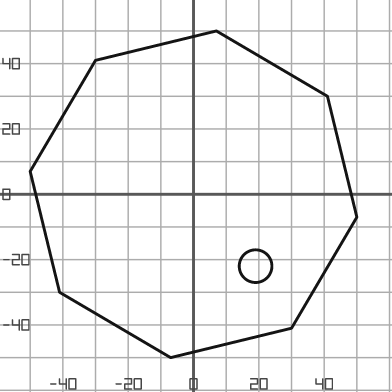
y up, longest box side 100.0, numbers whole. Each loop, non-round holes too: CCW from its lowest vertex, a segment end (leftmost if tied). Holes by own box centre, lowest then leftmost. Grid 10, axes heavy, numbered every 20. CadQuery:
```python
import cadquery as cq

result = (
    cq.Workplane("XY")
    .moveTo(-7.0, -50.0)
    .lineTo(30.0, -41.0)
    .lineTo(50.0, -7.0)
    .lineTo(41.0, 30.0)
    .lineTo(7.0, 50.0)
    .lineTo(-30.0, 41.0)
    .lineTo(-50.0, 7.0)
    .lineTo(-41.0, -30.0)
    .close()
    .moveTo(19.0, -22.0)
    .circle(5.0)
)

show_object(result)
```